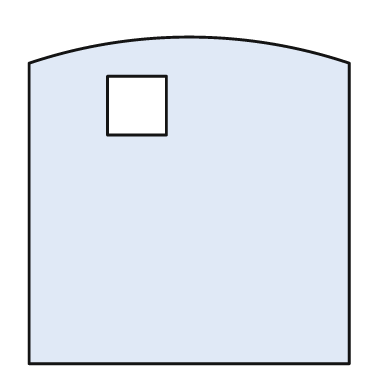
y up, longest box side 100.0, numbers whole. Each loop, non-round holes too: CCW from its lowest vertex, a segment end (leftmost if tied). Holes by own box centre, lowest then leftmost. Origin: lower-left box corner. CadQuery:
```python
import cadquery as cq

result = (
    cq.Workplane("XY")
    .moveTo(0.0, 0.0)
    .lineTo(98.0, 0.0)
    .lineTo(98.0, 92.0)
    .threePointArc((49.0, 100.0), (0.0, 92.0))
    .close()
    .moveTo(24.0, 70.0)
    .lineTo(42.0, 70.0)
    .lineTo(42.0, 88.0)
    .lineTo(24.0, 88.0)
    .close()
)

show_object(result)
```